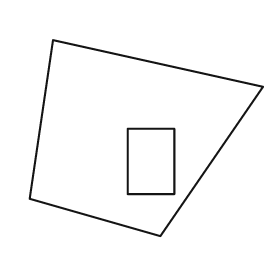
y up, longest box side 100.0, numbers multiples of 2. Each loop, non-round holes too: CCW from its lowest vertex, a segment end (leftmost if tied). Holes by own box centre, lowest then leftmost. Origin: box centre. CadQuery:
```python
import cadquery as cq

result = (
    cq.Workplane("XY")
    .moveTo(6.0, -42.0)
    .lineTo(50.0, 22.0)
    .lineTo(-40.0, 42.0)
    .lineTo(-50.0, -26.0)
    .close()
    .moveTo(-8.0, -24.0)
    .lineTo(12.0, -24.0)
    .lineTo(12.0, 4.0)
    .lineTo(-8.0, 4.0)
    .close()
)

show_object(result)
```